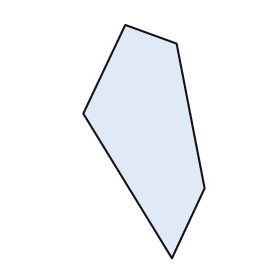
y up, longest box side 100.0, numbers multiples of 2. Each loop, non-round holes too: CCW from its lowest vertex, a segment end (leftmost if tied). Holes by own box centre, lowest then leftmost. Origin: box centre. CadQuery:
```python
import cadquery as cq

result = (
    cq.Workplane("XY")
    .moveTo(12.0, -50.0)
    .lineTo(26.0, -20.0)
    .lineTo(14.0, 42.0)
    .lineTo(-8.0, 50.0)
    .lineTo(-26.0, 12.0)
    .close()
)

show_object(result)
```